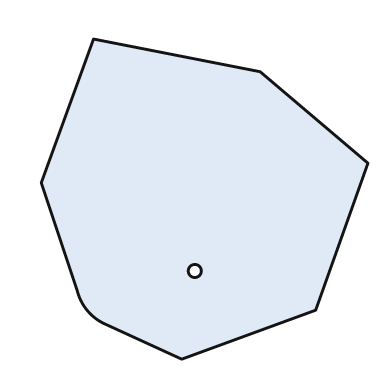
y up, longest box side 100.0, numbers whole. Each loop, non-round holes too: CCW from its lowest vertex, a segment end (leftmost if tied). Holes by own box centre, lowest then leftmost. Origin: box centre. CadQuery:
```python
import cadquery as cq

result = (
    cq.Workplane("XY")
    .moveTo(-7.0, -49.0)
    .lineTo(34.0, -34.0)
    .lineTo(50.0, 11.0)
    .lineTo(17.0, 39.0)
    .lineTo(-34.0, 49.0)
    .lineTo(-50.0, 5.0)
    .lineTo(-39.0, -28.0)
    .threePointArc((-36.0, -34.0), (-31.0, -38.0))
    .close()
    .moveTo(-3.0, -22.0)
    .circle(2.0)
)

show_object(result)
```